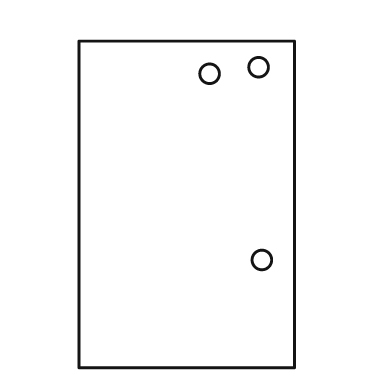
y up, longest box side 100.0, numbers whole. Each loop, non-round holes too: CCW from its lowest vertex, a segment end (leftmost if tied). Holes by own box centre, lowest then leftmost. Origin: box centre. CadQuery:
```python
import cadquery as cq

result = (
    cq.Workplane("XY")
    .moveTo(-33.0, -50.0)
    .lineTo(33.0, -50.0)
    .lineTo(33.0, 50.0)
    .lineTo(-33.0, 50.0)
    .close()
    .moveTo(23.0, -17.0)
    .circle(3.0)
    .moveTo(7.0, 40.0)
    .circle(3.0)
    .moveTo(22.0, 42.0)
    .circle(3.0)
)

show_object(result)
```